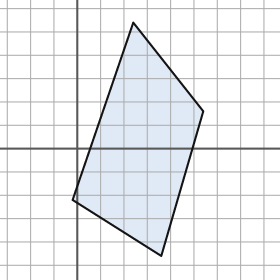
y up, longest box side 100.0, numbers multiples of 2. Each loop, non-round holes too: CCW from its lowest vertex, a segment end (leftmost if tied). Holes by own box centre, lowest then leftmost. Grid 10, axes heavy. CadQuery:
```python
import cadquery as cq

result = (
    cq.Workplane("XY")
    .moveTo(36.0, -46.0)
    .lineTo(54.0, 16.0)
    .lineTo(24.0, 54.0)
    .lineTo(-2.0, -22.0)
    .close()
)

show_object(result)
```